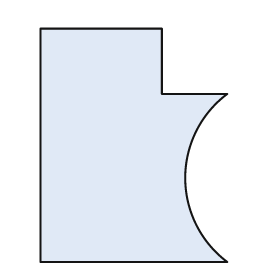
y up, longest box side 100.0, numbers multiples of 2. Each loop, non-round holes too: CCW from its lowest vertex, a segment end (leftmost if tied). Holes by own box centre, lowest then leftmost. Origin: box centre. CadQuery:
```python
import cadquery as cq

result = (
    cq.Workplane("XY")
    .moveTo(-40.0, -50.0)
    .lineTo(40.0, -50.0)
    .threePointArc((22.0, -14.0), (40.0, 22.0))
    .lineTo(12.0, 22.0)
    .lineTo(12.0, 50.0)
    .lineTo(-40.0, 50.0)
    .close()
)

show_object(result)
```